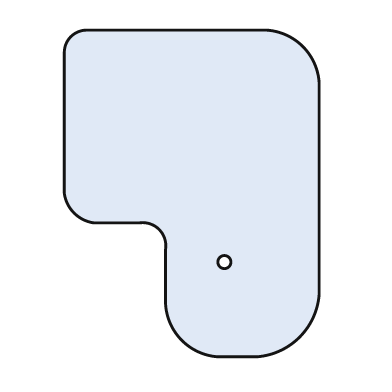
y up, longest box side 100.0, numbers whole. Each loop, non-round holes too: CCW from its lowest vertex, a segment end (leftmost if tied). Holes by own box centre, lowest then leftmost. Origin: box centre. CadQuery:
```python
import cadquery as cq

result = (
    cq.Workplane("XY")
    .moveTo(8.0, -50.0)
    .lineTo(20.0, -50.0)
    .threePointArc((33.0, -44.0), (39.0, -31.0))
    .lineTo(39.0, 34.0)
    .threePointArc((34.0, 45.0), (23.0, 50.0))
    .lineTo(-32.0, 50.0)
    .threePointArc((-37.0, 48.0), (-39.0, 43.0))
    .lineTo(-39.0, 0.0)
    .threePointArc((-36.0, -6.0), (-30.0, -9.0))
    .lineTo(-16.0, -9.0)
    .threePointArc((-10.0, -11.0), (-8.0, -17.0))
    .lineTo(-8.0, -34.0)
    .threePointArc((-3.0, -45.0), (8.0, -50.0))
    .close()
    .moveTo(10.0, -21.0)
    .circle(2.0)
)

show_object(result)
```